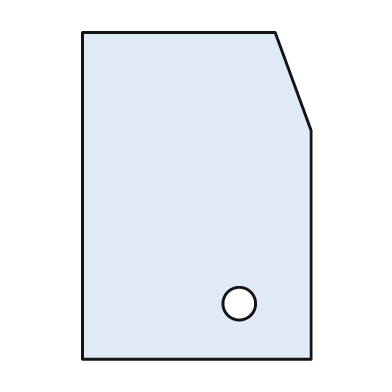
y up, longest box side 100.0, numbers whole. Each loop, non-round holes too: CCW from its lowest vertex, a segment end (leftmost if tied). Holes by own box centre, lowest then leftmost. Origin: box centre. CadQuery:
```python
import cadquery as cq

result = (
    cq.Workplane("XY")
    .moveTo(-35.0, -50.0)
    .lineTo(35.0, -50.0)
    .lineTo(35.0, 20.0)
    .lineTo(24.0, 50.0)
    .lineTo(-35.0, 50.0)
    .close()
    .moveTo(13.0, -33.0)
    .circle(5.0)
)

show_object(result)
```